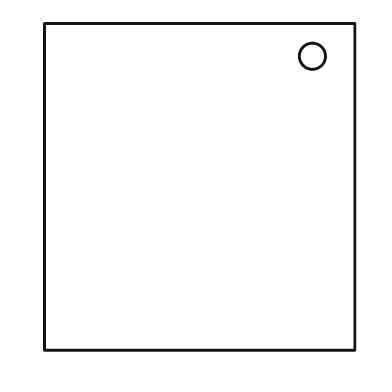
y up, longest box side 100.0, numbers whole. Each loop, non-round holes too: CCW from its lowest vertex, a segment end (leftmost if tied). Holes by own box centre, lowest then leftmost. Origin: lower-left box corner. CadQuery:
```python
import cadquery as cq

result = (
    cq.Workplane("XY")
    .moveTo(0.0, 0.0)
    .lineTo(95.0, 0.0)
    .lineTo(95.0, 100.0)
    .lineTo(0.0, 100.0)
    .close()
    .moveTo(82.0, 90.0)
    .circle(4.0)
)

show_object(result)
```